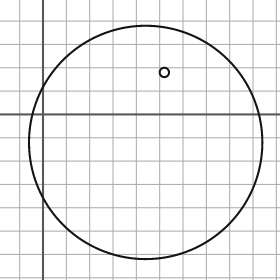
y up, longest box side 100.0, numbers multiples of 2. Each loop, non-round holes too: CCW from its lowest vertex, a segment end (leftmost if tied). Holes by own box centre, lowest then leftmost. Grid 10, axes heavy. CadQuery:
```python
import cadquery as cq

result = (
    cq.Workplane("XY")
    .moveTo(44.0, -12.0)
    .circle(50.0)
    .moveTo(52.0, 18.0)
    .circle(2.0)
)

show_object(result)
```